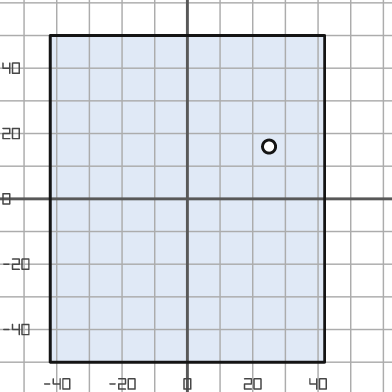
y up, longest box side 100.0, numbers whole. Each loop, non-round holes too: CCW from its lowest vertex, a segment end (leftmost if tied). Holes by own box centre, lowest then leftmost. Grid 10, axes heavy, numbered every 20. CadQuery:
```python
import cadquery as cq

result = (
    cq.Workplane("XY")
    .moveTo(-42.0, -50.0)
    .lineTo(42.0, -50.0)
    .lineTo(42.0, 50.0)
    .lineTo(-42.0, 50.0)
    .close()
    .moveTo(25.0, 16.0)
    .circle(2.0)
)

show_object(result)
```